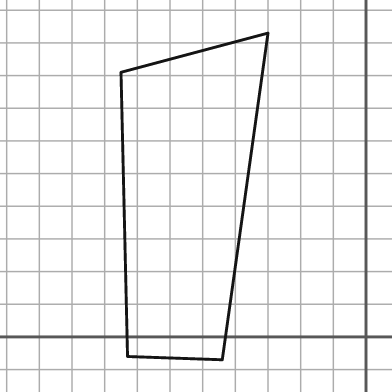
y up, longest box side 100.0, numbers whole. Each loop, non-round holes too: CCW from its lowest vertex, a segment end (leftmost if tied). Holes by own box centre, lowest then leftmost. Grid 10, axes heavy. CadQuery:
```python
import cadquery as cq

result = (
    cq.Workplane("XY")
    .moveTo(-44.0, -7.0)
    .lineTo(-30.0, 93.0)
    .lineTo(-75.0, 81.0)
    .lineTo(-73.0, -6.0)
    .close()
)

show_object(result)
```